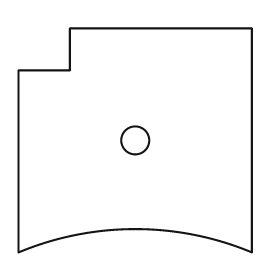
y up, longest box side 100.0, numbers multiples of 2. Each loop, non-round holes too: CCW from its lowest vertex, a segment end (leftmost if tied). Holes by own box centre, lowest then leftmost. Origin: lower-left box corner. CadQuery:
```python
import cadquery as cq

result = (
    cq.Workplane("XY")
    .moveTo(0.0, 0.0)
    .threePointArc((50.0, 10.0), (100.0, 0.0))
    .lineTo(100.0, 96.0)
    .lineTo(22.0, 96.0)
    .lineTo(22.0, 78.0)
    .lineTo(0.0, 78.0)
    .close()
    .moveTo(50.0, 48.0)
    .circle(6.0)
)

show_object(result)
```